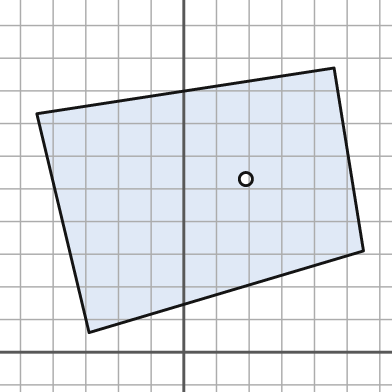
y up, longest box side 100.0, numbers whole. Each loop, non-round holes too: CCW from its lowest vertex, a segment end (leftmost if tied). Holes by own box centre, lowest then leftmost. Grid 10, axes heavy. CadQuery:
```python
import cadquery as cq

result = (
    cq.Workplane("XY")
    .moveTo(-29.0, 6.0)
    .lineTo(55.0, 31.0)
    .lineTo(46.0, 87.0)
    .lineTo(-45.0, 73.0)
    .close()
    .moveTo(19.0, 53.0)
    .circle(2.0)
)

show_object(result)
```